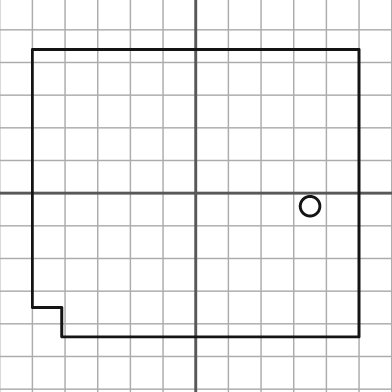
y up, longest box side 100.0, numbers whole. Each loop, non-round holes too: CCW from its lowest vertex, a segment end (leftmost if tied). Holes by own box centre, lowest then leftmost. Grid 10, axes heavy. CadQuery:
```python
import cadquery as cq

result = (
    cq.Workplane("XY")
    .moveTo(-41.0, -44.0)
    .lineTo(50.0, -44.0)
    .lineTo(50.0, 44.0)
    .lineTo(-50.0, 44.0)
    .lineTo(-50.0, -35.0)
    .lineTo(-41.0, -35.0)
    .close()
    .moveTo(35.0, -4.0)
    .circle(3.0)
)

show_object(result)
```